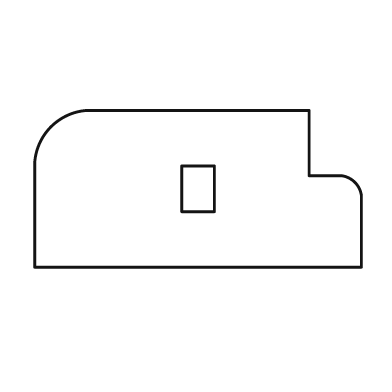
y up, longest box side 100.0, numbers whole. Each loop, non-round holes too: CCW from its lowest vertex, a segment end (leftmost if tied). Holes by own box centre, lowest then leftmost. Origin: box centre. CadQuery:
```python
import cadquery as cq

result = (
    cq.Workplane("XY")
    .moveTo(-50.0, -24.0)
    .lineTo(50.0, -24.0)
    .lineTo(50.0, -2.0)
    .threePointArc((48.0, 2.0), (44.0, 4.0))
    .lineTo(34.0, 4.0)
    .lineTo(34.0, 24.0)
    .lineTo(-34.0, 24.0)
    .threePointArc((-45.0, 19.0), (-50.0, 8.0))
    .close()
    .moveTo(-5.0, -7.0)
    .lineTo(5.0, -7.0)
    .lineTo(5.0, 7.0)
    .lineTo(-5.0, 7.0)
    .close()
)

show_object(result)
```